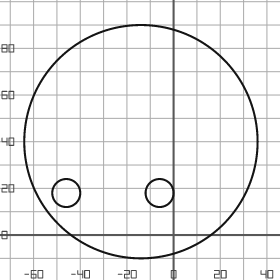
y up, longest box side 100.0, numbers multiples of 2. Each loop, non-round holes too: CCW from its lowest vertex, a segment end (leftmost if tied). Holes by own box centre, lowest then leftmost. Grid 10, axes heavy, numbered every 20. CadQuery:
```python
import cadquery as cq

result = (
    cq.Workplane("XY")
    .moveTo(-14.0, 40.0)
    .circle(50.0)
    .moveTo(-46.0, 18.0)
    .circle(6.0)
    .moveTo(-6.0, 18.0)
    .circle(6.0)
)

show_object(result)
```